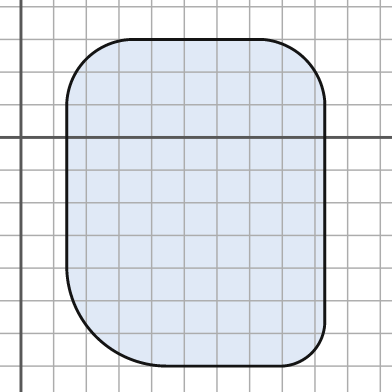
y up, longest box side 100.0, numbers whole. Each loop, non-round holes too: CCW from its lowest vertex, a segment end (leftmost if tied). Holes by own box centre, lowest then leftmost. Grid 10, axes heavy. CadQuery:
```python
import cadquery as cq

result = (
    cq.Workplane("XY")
    .moveTo(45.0, -70.0)
    .lineTo(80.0, -70.0)
    .threePointArc((89.0, -66.0), (93.0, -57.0))
    .lineTo(93.0, 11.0)
    .threePointArc((87.0, 24.0), (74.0, 30.0))
    .lineTo(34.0, 30.0)
    .threePointArc((20.0, 24.0), (14.0, 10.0))
    .lineTo(14.0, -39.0)
    .threePointArc((23.0, -61.0), (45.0, -70.0))
    .close()
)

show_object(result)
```